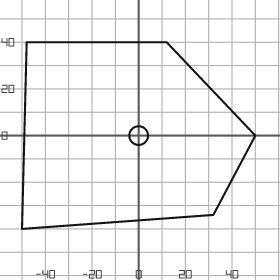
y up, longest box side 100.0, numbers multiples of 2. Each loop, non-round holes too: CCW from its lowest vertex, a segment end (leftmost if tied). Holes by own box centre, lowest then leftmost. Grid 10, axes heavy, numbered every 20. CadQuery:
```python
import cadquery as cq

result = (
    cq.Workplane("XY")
    .moveTo(-50.0, -40.0)
    .lineTo(32.0, -34.0)
    .lineTo(50.0, 0.0)
    .lineTo(12.0, 40.0)
    .lineTo(-48.0, 40.0)
    .close()
    .moveTo(0.0, 0.0)
    .circle(4.0)
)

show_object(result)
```